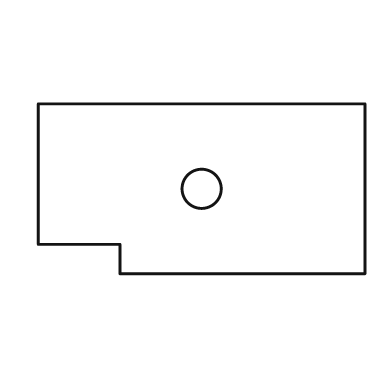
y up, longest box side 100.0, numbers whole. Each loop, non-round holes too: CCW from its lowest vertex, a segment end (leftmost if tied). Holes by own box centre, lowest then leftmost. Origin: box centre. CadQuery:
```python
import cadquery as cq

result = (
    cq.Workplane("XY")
    .moveTo(-25.0, -26.0)
    .lineTo(50.0, -26.0)
    .lineTo(50.0, 26.0)
    .lineTo(-50.0, 26.0)
    .lineTo(-50.0, -17.0)
    .lineTo(-25.0, -17.0)
    .close()
    .moveTo(0.0, 0.0)
    .circle(6.0)
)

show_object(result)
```